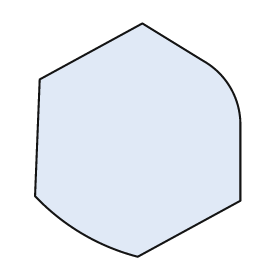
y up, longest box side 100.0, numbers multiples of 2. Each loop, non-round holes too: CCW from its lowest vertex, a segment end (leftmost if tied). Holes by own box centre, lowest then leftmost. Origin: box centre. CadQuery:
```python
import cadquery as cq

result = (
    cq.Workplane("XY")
    .moveTo(0.0, -50.0)
    .lineTo(44.0, -26.0)
    .lineTo(44.0, 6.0)
    .threePointArc((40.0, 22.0), (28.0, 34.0))
    .lineTo(2.0, 50.0)
    .lineTo(-42.0, 26.0)
    .lineTo(-44.0, -24.0)
    .threePointArc((-24.0, -40.0), (0.0, -50.0))
    .close()
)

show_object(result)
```